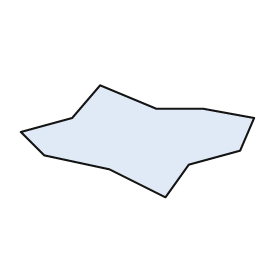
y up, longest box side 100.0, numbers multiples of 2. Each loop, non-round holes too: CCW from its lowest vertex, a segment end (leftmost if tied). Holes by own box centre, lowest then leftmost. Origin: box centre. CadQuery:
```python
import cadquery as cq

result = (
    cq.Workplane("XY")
    .moveTo(12.0, -24.0)
    .lineTo(22.0, -10.0)
    .lineTo(44.0, -4.0)
    .lineTo(50.0, 10.0)
    .lineTo(28.0, 14.0)
    .lineTo(8.0, 14.0)
    .lineTo(-16.0, 24.0)
    .lineTo(-28.0, 10.0)
    .lineTo(-50.0, 4.0)
    .lineTo(-40.0, -6.0)
    .lineTo(-12.0, -12.0)
    .close()
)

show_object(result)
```